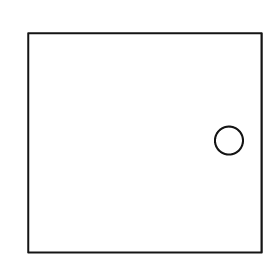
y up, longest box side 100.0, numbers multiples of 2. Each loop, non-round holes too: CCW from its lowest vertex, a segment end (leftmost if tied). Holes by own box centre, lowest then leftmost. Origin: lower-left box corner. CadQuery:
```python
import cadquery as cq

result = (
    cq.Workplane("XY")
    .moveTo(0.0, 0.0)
    .lineTo(100.0, 0.0)
    .lineTo(100.0, 94.0)
    .lineTo(0.0, 94.0)
    .close()
    .moveTo(86.0, 48.0)
    .circle(6.0)
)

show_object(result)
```